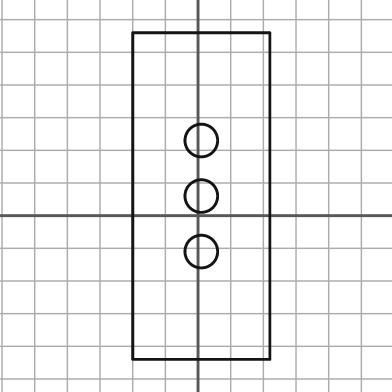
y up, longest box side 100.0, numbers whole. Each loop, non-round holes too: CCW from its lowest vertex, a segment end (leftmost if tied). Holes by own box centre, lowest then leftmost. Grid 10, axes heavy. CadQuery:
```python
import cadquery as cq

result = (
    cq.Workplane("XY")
    .moveTo(-20.0, -44.0)
    .lineTo(22.0, -44.0)
    .lineTo(22.0, 56.0)
    .lineTo(-20.0, 56.0)
    .close()
    .moveTo(1.0, -11.0)
    .circle(5.0)
    .moveTo(1.0, 6.0)
    .circle(5.0)
    .moveTo(1.0, 23.0)
    .circle(5.0)
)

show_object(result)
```